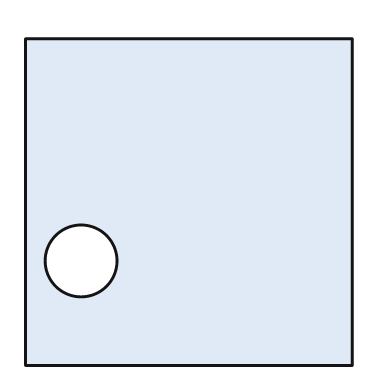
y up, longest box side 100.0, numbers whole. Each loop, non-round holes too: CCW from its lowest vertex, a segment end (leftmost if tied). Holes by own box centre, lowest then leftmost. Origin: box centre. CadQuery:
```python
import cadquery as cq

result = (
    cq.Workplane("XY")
    .moveTo(-50.0, -50.0)
    .lineTo(50.0, -50.0)
    .lineTo(50.0, 50.0)
    .lineTo(-50.0, 50.0)
    .close()
    .moveTo(-33.0, -18.0)
    .circle(11.0)
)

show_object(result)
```